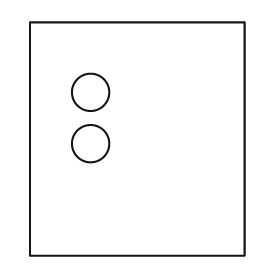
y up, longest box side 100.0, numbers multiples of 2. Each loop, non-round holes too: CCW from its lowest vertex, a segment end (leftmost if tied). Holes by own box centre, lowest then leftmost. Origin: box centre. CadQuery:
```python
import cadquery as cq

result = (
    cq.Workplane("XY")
    .moveTo(-46.0, -50.0)
    .lineTo(46.0, -50.0)
    .lineTo(46.0, 50.0)
    .lineTo(-46.0, 50.0)
    .close()
    .moveTo(-20.0, -2.0)
    .circle(8.0)
    .moveTo(-20.0, 20.0)
    .circle(8.0)
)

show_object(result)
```